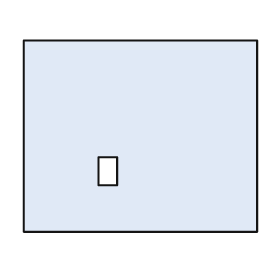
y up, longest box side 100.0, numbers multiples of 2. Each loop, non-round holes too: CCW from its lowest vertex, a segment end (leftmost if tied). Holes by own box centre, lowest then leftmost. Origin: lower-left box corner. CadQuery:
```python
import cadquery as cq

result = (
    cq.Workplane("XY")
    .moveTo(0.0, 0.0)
    .lineTo(100.0, 0.0)
    .lineTo(100.0, 82.0)
    .lineTo(0.0, 82.0)
    .close()
    .moveTo(32.0, 20.0)
    .lineTo(40.0, 20.0)
    .lineTo(40.0, 32.0)
    .lineTo(32.0, 32.0)
    .close()
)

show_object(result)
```